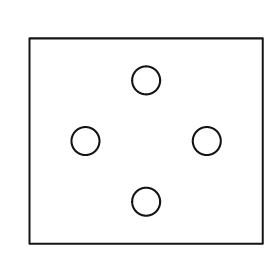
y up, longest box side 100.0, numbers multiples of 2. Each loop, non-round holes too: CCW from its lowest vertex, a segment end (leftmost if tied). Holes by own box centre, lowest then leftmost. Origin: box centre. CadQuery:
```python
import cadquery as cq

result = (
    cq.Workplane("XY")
    .moveTo(-50.0, -44.0)
    .lineTo(50.0, -44.0)
    .lineTo(50.0, 44.0)
    .lineTo(-50.0, 44.0)
    .close()
    .moveTo(0.0, -26.0)
    .circle(6.0)
    .moveTo(-26.0, 0.0)
    .circle(6.0)
    .moveTo(26.0, 0.0)
    .circle(6.0)
    .moveTo(0.0, 26.0)
    .circle(6.0)
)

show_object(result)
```